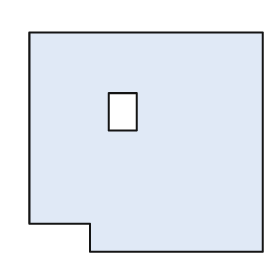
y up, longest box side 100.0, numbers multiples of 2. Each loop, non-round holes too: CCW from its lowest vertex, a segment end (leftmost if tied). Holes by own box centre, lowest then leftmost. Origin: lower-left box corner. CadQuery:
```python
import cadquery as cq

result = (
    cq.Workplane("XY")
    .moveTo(26.0, 0.0)
    .lineTo(100.0, 0.0)
    .lineTo(100.0, 94.0)
    .lineTo(0.0, 94.0)
    .lineTo(0.0, 12.0)
    .lineTo(26.0, 12.0)
    .close()
    .moveTo(34.0, 52.0)
    .lineTo(46.0, 52.0)
    .lineTo(46.0, 68.0)
    .lineTo(34.0, 68.0)
    .close()
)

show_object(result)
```